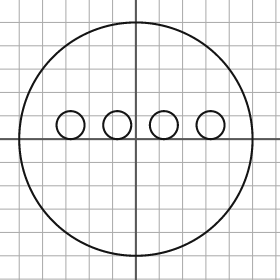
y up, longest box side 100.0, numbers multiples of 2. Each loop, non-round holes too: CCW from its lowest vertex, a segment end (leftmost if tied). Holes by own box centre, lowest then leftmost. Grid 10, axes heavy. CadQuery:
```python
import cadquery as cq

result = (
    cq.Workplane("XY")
    .moveTo(0.0, 0.0)
    .circle(50.0)
    .moveTo(-28.0, 6.0)
    .circle(6.0)
    .moveTo(-8.0, 6.0)
    .circle(6.0)
    .moveTo(12.0, 6.0)
    .circle(6.0)
    .moveTo(32.0, 6.0)
    .circle(6.0)
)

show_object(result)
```